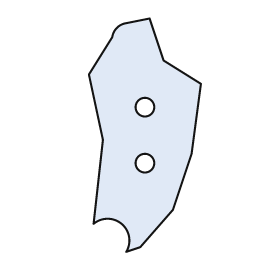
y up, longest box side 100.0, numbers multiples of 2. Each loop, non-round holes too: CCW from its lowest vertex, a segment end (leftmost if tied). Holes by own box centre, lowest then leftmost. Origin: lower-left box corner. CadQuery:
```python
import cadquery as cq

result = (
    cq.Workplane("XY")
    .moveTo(16.0, 0.0)
    .lineTo(22.0, 2.0)
    .lineTo(36.0, 18.0)
    .lineTo(44.0, 42.0)
    .lineTo(48.0, 72.0)
    .lineTo(32.0, 82.0)
    .lineTo(26.0, 100.0)
    .lineTo(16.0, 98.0)
    .threePointArc((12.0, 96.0), (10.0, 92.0))
    .lineTo(0.0, 76.0)
    .lineTo(6.0, 48.0)
    .lineTo(2.0, 12.0)
    .threePointArc((14.0, 12.0), (16.0, 0.0))
    .close()
    .moveTo(24.0, 38.0)
    .circle(4.0)
    .moveTo(24.0, 62.0)
    .circle(4.0)
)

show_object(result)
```